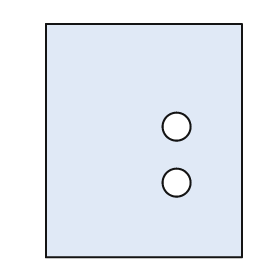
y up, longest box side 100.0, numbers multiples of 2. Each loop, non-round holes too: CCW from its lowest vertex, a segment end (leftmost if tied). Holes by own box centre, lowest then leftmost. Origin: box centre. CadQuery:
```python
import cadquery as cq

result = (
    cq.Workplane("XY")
    .moveTo(-42.0, -50.0)
    .lineTo(42.0, -50.0)
    .lineTo(42.0, 50.0)
    .lineTo(-42.0, 50.0)
    .close()
    .moveTo(14.0, -18.0)
    .circle(6.0)
    .moveTo(14.0, 6.0)
    .circle(6.0)
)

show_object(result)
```